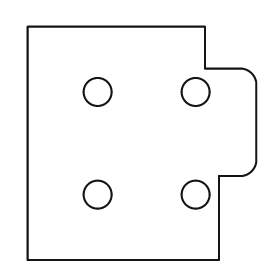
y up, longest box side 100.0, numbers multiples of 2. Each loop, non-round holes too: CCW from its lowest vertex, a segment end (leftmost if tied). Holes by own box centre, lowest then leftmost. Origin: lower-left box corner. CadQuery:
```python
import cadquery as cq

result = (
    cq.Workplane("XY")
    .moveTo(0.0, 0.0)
    .lineTo(82.0, 0.0)
    .lineTo(82.0, 36.0)
    .lineTo(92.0, 36.0)
    .threePointArc((96.0, 38.0), (98.0, 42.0))
    .lineTo(98.0, 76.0)
    .threePointArc((96.0, 80.0), (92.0, 82.0))
    .lineTo(76.0, 82.0)
    .lineTo(76.0, 100.0)
    .lineTo(0.0, 100.0)
    .close()
    .moveTo(30.0, 28.0)
    .circle(6.0)
    .moveTo(72.0, 28.0)
    .circle(6.0)
    .moveTo(30.0, 72.0)
    .circle(6.0)
    .moveTo(72.0, 72.0)
    .circle(6.0)
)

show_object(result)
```